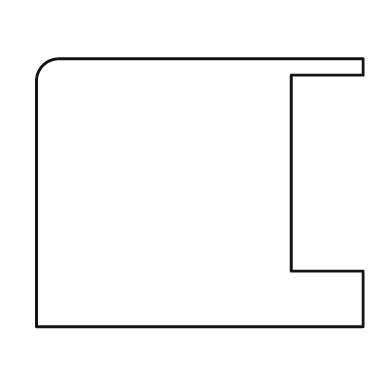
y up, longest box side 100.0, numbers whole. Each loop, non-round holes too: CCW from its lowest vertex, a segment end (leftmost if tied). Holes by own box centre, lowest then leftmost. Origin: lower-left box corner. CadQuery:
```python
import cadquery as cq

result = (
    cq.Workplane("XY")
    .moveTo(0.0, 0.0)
    .lineTo(100.0, 0.0)
    .lineTo(100.0, 17.0)
    .lineTo(78.0, 17.0)
    .lineTo(78.0, 77.0)
    .lineTo(100.0, 77.0)
    .lineTo(100.0, 82.0)
    .lineTo(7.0, 82.0)
    .threePointArc((2.0, 80.0), (0.0, 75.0))
    .close()
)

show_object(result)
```